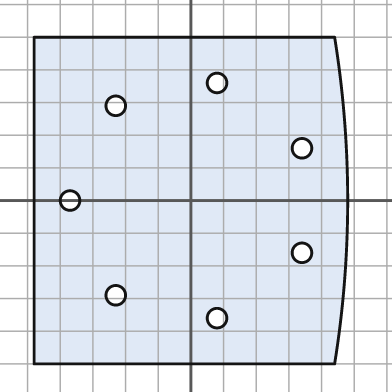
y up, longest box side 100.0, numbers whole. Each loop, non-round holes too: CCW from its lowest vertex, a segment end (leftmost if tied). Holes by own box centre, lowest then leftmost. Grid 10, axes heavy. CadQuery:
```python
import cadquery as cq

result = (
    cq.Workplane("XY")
    .moveTo(-48.0, -50.0)
    .lineTo(44.0, -50.0)
    .threePointArc((48.0, 0.0), (44.0, 50.0))
    .lineTo(-48.0, 50.0)
    .close()
    .moveTo(8.0, -36.0)
    .circle(3.0)
    .moveTo(-23.0, -29.0)
    .circle(3.0)
    .moveTo(34.0, -16.0)
    .circle(3.0)
    .moveTo(-37.0, 0.0)
    .circle(3.0)
    .moveTo(34.0, 16.0)
    .circle(3.0)
    .moveTo(-23.0, 29.0)
    .circle(3.0)
    .moveTo(8.0, 36.0)
    .circle(3.0)
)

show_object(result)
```